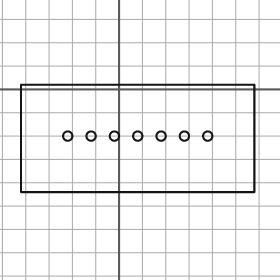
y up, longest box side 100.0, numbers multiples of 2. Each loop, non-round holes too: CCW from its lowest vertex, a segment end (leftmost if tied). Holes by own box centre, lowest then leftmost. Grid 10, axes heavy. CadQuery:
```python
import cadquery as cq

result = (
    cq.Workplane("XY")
    .moveTo(-42.0, -44.0)
    .lineTo(58.0, -44.0)
    .lineTo(58.0, 2.0)
    .lineTo(-42.0, 2.0)
    .close()
    .moveTo(-22.0, -20.0)
    .circle(2.0)
    .moveTo(-12.0, -20.0)
    .circle(2.0)
    .moveTo(-2.0, -20.0)
    .circle(2.0)
    .moveTo(8.0, -20.0)
    .circle(2.0)
    .moveTo(18.0, -20.0)
    .circle(2.0)
    .moveTo(28.0, -20.0)
    .circle(2.0)
    .moveTo(38.0, -20.0)
    .circle(2.0)
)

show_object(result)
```